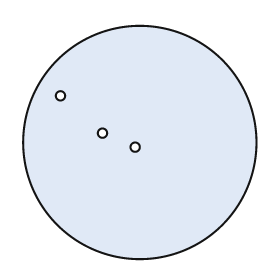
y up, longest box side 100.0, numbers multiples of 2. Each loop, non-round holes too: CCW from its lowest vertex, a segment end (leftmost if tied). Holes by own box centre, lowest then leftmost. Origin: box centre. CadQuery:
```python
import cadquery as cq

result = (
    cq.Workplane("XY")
    .moveTo(0.0, 0.0)
    .circle(50.0)
    .moveTo(-2.0, -2.0)
    .circle(2.0)
    .moveTo(-16.0, 4.0)
    .circle(2.0)
    .moveTo(-34.0, 20.0)
    .circle(2.0)
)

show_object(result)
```